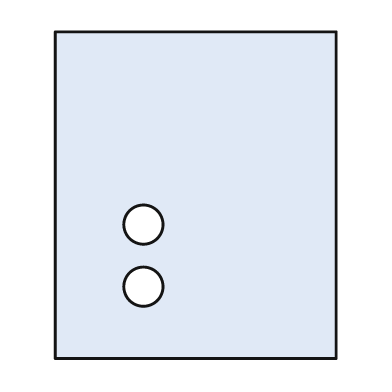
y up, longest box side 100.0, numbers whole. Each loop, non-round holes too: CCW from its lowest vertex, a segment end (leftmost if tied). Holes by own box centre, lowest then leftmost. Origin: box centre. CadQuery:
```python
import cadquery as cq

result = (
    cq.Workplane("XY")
    .moveTo(-43.0, -50.0)
    .lineTo(43.0, -50.0)
    .lineTo(43.0, 50.0)
    .lineTo(-43.0, 50.0)
    .close()
    .moveTo(-16.0, -28.0)
    .circle(6.0)
    .moveTo(-16.0, -9.0)
    .circle(6.0)
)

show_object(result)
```